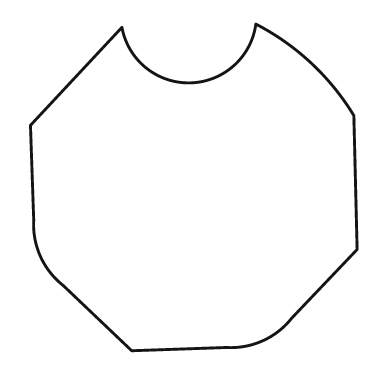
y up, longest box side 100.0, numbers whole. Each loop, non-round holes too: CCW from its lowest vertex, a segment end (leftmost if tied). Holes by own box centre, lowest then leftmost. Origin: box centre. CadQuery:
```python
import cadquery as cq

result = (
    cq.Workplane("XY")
    .moveTo(-19.0, -50.0)
    .lineTo(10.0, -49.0)
    .threePointArc((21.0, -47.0), (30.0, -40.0))
    .lineTo(50.0, -19.0)
    .lineTo(49.0, 22.0)
    .threePointArc((36.0, 38.0), (19.0, 50.0))
    .threePointArc((-1.0, 32.0), (-22.0, 49.0))
    .lineTo(-50.0, 19.0)
    .lineTo(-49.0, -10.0)
    .threePointArc((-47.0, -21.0), (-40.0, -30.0))
    .close()
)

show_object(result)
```